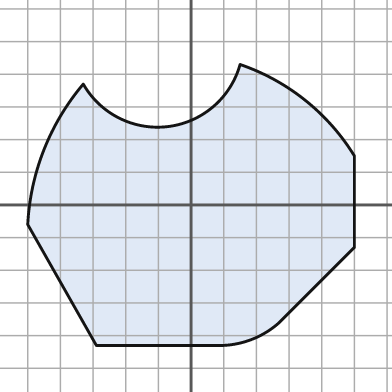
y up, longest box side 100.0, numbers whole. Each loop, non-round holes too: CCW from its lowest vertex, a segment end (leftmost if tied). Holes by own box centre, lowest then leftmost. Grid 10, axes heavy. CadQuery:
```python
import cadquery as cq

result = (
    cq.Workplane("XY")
    .moveTo(-29.0, -43.0)
    .lineTo(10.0, -43.0)
    .threePointArc((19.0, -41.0), (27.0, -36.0))
    .lineTo(50.0, -13.0)
    .lineTo(50.0, 15.0)
    .threePointArc((35.0, 32.0), (15.0, 43.0))
    .threePointArc((-7.0, 24.0), (-33.0, 37.0))
    .threePointArc((-45.0, 17.0), (-50.0, -6.0))
    .close()
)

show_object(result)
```